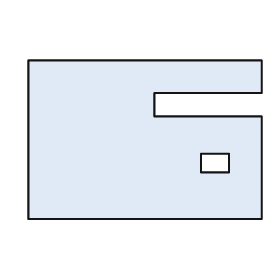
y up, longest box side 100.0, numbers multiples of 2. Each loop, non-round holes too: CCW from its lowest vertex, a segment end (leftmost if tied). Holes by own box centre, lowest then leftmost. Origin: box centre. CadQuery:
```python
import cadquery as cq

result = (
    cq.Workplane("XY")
    .moveTo(-50.0, -34.0)
    .lineTo(50.0, -34.0)
    .lineTo(50.0, 10.0)
    .lineTo(4.0, 10.0)
    .lineTo(4.0, 20.0)
    .lineTo(50.0, 20.0)
    .lineTo(50.0, 34.0)
    .lineTo(-50.0, 34.0)
    .close()
    .moveTo(24.0, -14.0)
    .lineTo(36.0, -14.0)
    .lineTo(36.0, -6.0)
    .lineTo(24.0, -6.0)
    .close()
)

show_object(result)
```